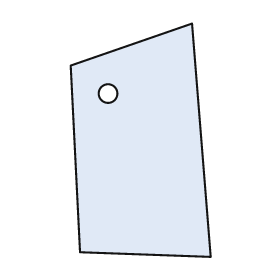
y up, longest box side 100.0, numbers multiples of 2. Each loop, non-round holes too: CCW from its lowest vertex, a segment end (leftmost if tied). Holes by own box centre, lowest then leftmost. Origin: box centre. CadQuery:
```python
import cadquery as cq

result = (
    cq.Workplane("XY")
    .moveTo(30.0, -50.0)
    .lineTo(22.0, 50.0)
    .lineTo(-30.0, 32.0)
    .lineTo(-26.0, -48.0)
    .close()
    .moveTo(-14.0, 20.0)
    .circle(4.0)
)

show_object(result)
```